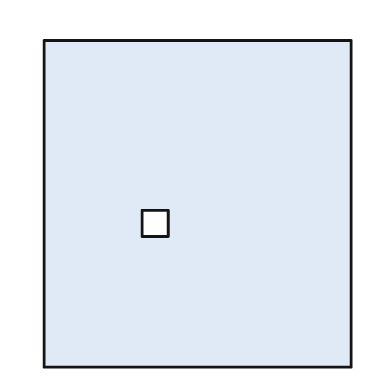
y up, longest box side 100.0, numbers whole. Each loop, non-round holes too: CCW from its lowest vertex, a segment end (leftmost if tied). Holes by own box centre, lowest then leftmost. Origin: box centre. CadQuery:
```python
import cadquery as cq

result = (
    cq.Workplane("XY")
    .moveTo(-47.0, -50.0)
    .lineTo(47.0, -50.0)
    .lineTo(47.0, 50.0)
    .lineTo(-47.0, 50.0)
    .close()
    .moveTo(-17.0, -10.0)
    .lineTo(-9.0, -10.0)
    .lineTo(-9.0, -2.0)
    .lineTo(-17.0, -2.0)
    .close()
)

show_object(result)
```